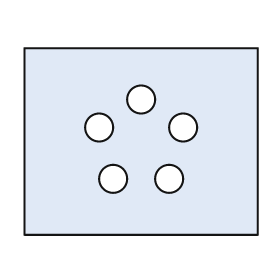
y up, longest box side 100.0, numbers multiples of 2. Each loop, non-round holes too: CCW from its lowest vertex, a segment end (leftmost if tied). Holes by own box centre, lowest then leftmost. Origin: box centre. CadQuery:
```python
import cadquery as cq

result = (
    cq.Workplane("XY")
    .moveTo(-50.0, -40.0)
    .lineTo(50.0, -40.0)
    .lineTo(50.0, 40.0)
    .lineTo(-50.0, 40.0)
    .close()
    .moveTo(-12.0, -16.0)
    .circle(6.0)
    .moveTo(12.0, -16.0)
    .circle(6.0)
    .moveTo(-18.0, 6.0)
    .circle(6.0)
    .moveTo(18.0, 6.0)
    .circle(6.0)
    .moveTo(0.0, 18.0)
    .circle(6.0)
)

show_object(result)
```